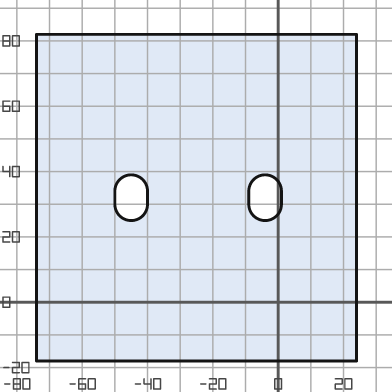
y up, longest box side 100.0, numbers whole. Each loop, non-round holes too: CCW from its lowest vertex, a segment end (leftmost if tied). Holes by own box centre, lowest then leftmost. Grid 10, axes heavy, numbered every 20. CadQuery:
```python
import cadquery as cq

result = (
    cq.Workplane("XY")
    .moveTo(-74.0, -18.0)
    .lineTo(24.0, -18.0)
    .lineTo(24.0, 82.0)
    .lineTo(-74.0, 82.0)
    .close()
    .moveTo(-50.0, 30.0)
    .threePointArc((-45.0, 25.0), (-40.0, 30.0))
    .lineTo(-40.0, 34.0)
    .threePointArc((-45.0, 39.0), (-50.0, 34.0))
    .close()
    .moveTo(-9.0, 30.0)
    .threePointArc((-4.0, 25.0), (1.0, 30.0))
    .lineTo(1.0, 34.0)
    .threePointArc((-4.0, 39.0), (-9.0, 34.0))
    .close()
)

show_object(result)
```